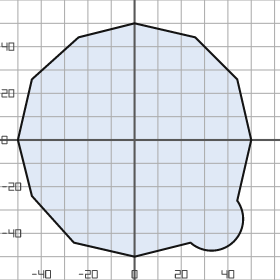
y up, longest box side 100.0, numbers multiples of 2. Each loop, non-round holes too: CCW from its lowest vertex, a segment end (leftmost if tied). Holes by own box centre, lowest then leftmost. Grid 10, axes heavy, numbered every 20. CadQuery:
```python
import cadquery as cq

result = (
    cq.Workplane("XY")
    .moveTo(0.0, -50.0)
    .lineTo(24.0, -44.0)
    .threePointArc((42.0, -44.0), (44.0, -26.0))
    .lineTo(50.0, 0.0)
    .lineTo(44.0, 26.0)
    .lineTo(26.0, 44.0)
    .lineTo(0.0, 50.0)
    .lineTo(-24.0, 44.0)
    .lineTo(-44.0, 26.0)
    .lineTo(-50.0, 0.0)
    .lineTo(-44.0, -24.0)
    .lineTo(-26.0, -44.0)
    .close()
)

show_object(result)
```